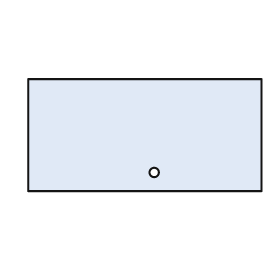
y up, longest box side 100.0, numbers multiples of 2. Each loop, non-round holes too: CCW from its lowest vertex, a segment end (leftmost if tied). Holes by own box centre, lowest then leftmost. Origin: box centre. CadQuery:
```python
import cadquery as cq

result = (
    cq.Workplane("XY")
    .moveTo(-50.0, -24.0)
    .lineTo(50.0, -24.0)
    .lineTo(50.0, 24.0)
    .lineTo(-50.0, 24.0)
    .close()
    .moveTo(4.0, -16.0)
    .circle(2.0)
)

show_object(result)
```